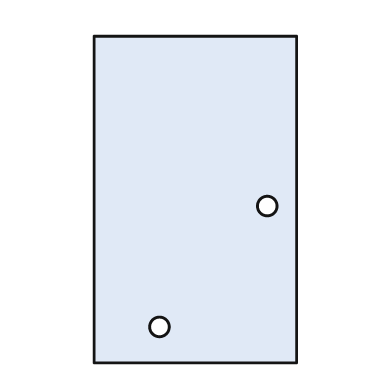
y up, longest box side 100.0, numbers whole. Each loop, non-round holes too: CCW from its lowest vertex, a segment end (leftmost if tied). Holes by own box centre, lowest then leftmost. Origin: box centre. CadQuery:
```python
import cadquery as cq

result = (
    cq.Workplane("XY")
    .moveTo(-31.0, -50.0)
    .lineTo(31.0, -50.0)
    .lineTo(31.0, 50.0)
    .lineTo(-31.0, 50.0)
    .close()
    .moveTo(-11.0, -39.0)
    .circle(3.0)
    .moveTo(22.0, -2.0)
    .circle(3.0)
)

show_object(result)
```